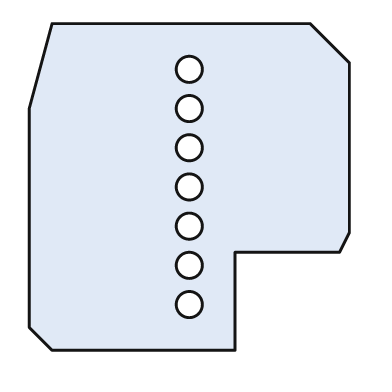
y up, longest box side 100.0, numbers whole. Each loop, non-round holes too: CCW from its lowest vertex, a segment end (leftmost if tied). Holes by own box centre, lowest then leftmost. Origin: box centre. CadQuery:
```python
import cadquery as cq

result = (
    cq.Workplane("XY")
    .moveTo(-42.0, -50.0)
    .lineTo(14.0, -50.0)
    .lineTo(14.0, -20.0)
    .lineTo(46.0, -20.0)
    .lineTo(49.0, -14.0)
    .lineTo(49.0, 38.0)
    .lineTo(37.0, 50.0)
    .lineTo(-42.0, 50.0)
    .lineTo(-49.0, 24.0)
    .lineTo(-49.0, -43.0)
    .close()
    .moveTo(0.0, -36.0)
    .circle(4.0)
    .moveTo(0.0, -24.0)
    .circle(4.0)
    .moveTo(0.0, -12.0)
    .circle(4.0)
    .moveTo(0.0, 0.0)
    .circle(4.0)
    .moveTo(0.0, 12.0)
    .circle(4.0)
    .moveTo(0.0, 24.0)
    .circle(4.0)
    .moveTo(0.0, 36.0)
    .circle(4.0)
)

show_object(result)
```